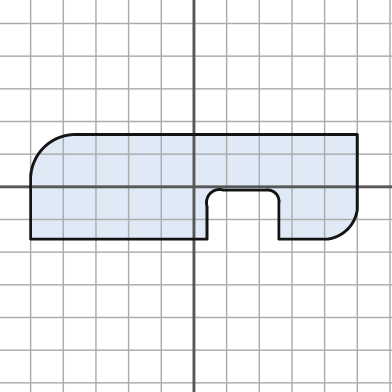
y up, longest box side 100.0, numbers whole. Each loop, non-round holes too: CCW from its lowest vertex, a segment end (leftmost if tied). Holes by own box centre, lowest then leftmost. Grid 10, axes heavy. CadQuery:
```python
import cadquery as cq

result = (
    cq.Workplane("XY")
    .moveTo(-50.0, -16.0)
    .lineTo(4.0, -16.0)
    .lineTo(4.0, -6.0)
    .threePointArc((5.0, -2.0), (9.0, -1.0))
    .lineTo(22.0, -1.0)
    .threePointArc((25.0, -2.0), (26.0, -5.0))
    .lineTo(26.0, -16.0)
    .lineTo(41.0, -16.0)
    .threePointArc((47.0, -13.0), (50.0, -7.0))
    .lineTo(50.0, 16.0)
    .lineTo(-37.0, 16.0)
    .threePointArc((-46.0, 12.0), (-50.0, 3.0))
    .close()
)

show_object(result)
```